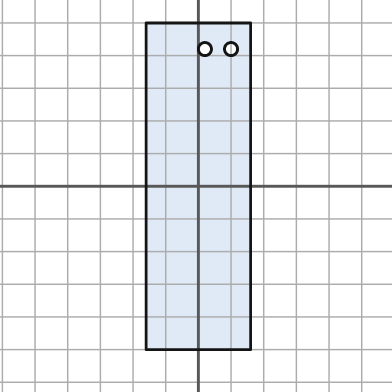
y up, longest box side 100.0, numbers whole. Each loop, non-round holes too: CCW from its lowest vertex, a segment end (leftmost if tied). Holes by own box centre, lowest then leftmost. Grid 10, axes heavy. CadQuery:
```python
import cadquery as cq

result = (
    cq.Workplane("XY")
    .moveTo(-16.0, -50.0)
    .lineTo(16.0, -50.0)
    .lineTo(16.0, 50.0)
    .lineTo(-16.0, 50.0)
    .close()
    .moveTo(2.0, 42.0)
    .circle(2.0)
    .moveTo(10.0, 42.0)
    .circle(2.0)
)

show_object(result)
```